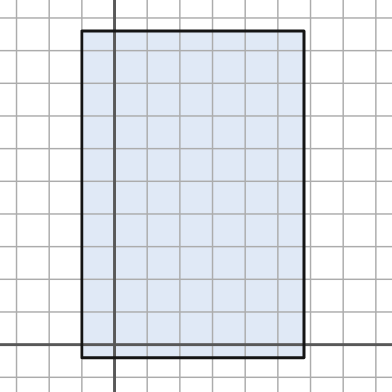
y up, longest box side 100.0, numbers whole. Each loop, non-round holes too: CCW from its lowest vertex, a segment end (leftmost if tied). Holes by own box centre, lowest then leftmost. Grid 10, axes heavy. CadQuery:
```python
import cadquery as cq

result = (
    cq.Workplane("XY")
    .moveTo(-10.0, -4.0)
    .lineTo(58.0, -4.0)
    .lineTo(58.0, 96.0)
    .lineTo(-10.0, 96.0)
    .close()
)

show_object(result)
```